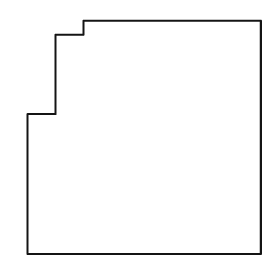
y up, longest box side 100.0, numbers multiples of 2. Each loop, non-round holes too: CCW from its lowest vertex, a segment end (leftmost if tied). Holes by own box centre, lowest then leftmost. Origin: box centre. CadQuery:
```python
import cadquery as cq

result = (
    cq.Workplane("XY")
    .moveTo(-50.0, -50.0)
    .lineTo(50.0, -50.0)
    .lineTo(50.0, 50.0)
    .lineTo(-26.0, 50.0)
    .lineTo(-26.0, 44.0)
    .lineTo(-38.0, 44.0)
    .lineTo(-38.0, 10.0)
    .lineTo(-50.0, 10.0)
    .close()
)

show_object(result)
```